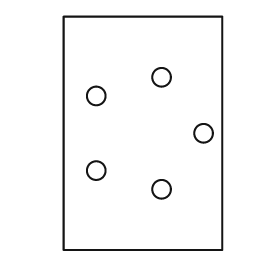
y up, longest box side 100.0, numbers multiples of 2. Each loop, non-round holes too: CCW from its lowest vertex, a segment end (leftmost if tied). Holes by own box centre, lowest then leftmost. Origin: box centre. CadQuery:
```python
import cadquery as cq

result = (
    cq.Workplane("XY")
    .moveTo(-34.0, -50.0)
    .lineTo(34.0, -50.0)
    .lineTo(34.0, 50.0)
    .lineTo(-34.0, 50.0)
    .close()
    .moveTo(8.0, -24.0)
    .circle(4.0)
    .moveTo(-20.0, -16.0)
    .circle(4.0)
    .moveTo(26.0, 0.0)
    .circle(4.0)
    .moveTo(-20.0, 16.0)
    .circle(4.0)
    .moveTo(8.0, 24.0)
    .circle(4.0)
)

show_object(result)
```